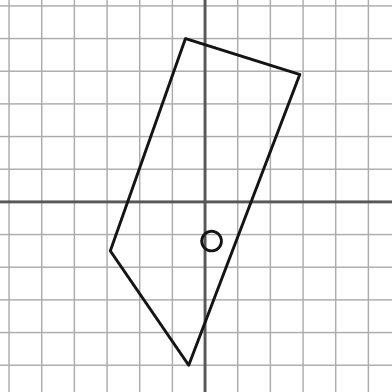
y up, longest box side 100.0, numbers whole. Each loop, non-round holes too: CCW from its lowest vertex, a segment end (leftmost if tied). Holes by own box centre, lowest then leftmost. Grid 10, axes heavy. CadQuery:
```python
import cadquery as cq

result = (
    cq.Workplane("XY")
    .moveTo(-5.0, -50.0)
    .lineTo(29.0, 39.0)
    .lineTo(-6.0, 50.0)
    .lineTo(-29.0, -15.0)
    .close()
    .moveTo(2.0, -12.0)
    .circle(3.0)
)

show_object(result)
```